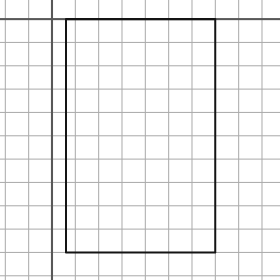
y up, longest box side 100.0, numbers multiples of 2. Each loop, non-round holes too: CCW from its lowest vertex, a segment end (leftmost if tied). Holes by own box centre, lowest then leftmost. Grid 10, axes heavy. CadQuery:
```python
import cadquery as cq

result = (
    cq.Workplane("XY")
    .moveTo(6.0, -100.0)
    .lineTo(70.0, -100.0)
    .lineTo(70.0, 0.0)
    .lineTo(6.0, 0.0)
    .close()
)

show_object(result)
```